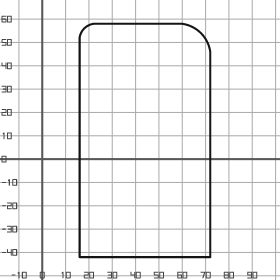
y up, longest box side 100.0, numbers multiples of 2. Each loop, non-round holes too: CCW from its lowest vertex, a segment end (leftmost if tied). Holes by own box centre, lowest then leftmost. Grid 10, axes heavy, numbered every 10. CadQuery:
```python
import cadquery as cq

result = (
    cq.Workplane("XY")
    .moveTo(16.0, -42.0)
    .lineTo(72.0, -42.0)
    .lineTo(72.0, 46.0)
    .threePointArc((68.0, 54.0), (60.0, 58.0))
    .lineTo(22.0, 58.0)
    .threePointArc((18.0, 56.0), (16.0, 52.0))
    .close()
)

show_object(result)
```